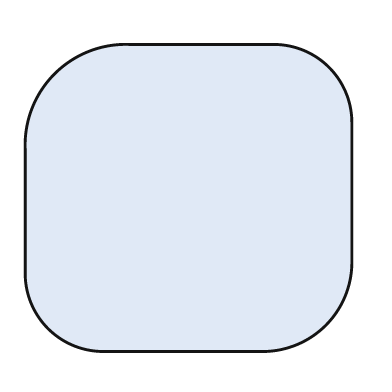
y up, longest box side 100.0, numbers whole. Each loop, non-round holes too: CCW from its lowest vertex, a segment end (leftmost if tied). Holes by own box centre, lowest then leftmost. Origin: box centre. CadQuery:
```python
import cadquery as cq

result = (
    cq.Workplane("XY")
    .moveTo(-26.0, -47.0)
    .lineTo(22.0, -47.0)
    .threePointArc((42.0, -39.0), (50.0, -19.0))
    .lineTo(50.0, 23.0)
    .threePointArc((43.0, 40.0), (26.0, 47.0))
    .lineTo(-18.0, 47.0)
    .threePointArc((-41.0, 38.0), (-50.0, 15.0))
    .lineTo(-50.0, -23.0)
    .threePointArc((-43.0, -40.0), (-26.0, -47.0))
    .close()
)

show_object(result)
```